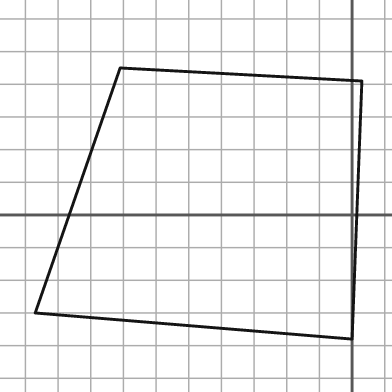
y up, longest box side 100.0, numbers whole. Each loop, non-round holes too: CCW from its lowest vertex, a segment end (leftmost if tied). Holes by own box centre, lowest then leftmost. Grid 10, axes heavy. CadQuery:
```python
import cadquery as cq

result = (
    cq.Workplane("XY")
    .moveTo(0.0, -38.0)
    .lineTo(3.0, 41.0)
    .lineTo(-71.0, 45.0)
    .lineTo(-97.0, -30.0)
    .close()
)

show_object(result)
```